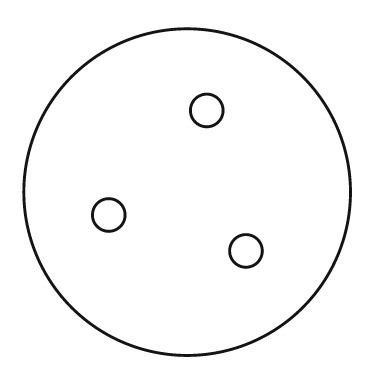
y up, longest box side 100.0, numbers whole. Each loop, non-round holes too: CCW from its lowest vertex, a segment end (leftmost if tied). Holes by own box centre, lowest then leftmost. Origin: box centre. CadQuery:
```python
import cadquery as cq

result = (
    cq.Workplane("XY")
    .moveTo(0.0, 0.0)
    .circle(50.0)
    .moveTo(18.0, -18.0)
    .circle(5.0)
    .moveTo(-24.0, -7.0)
    .circle(5.0)
    .moveTo(6.0, 25.0)
    .circle(5.0)
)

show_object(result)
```